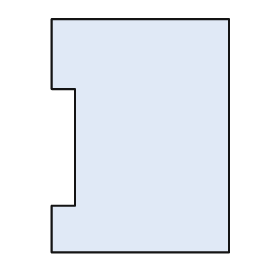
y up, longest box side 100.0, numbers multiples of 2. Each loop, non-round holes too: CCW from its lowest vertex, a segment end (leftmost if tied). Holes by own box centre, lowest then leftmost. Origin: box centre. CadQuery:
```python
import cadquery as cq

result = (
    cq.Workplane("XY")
    .moveTo(-38.0, -50.0)
    .lineTo(38.0, -50.0)
    .lineTo(38.0, 50.0)
    .lineTo(-38.0, 50.0)
    .lineTo(-38.0, 20.0)
    .lineTo(-28.0, 20.0)
    .lineTo(-28.0, -30.0)
    .lineTo(-38.0, -30.0)
    .close()
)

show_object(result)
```